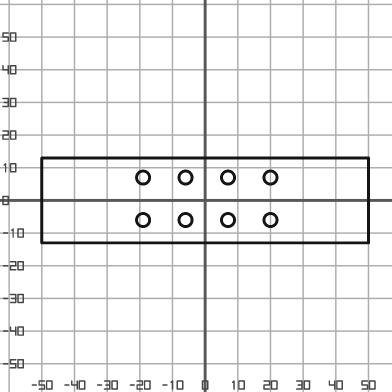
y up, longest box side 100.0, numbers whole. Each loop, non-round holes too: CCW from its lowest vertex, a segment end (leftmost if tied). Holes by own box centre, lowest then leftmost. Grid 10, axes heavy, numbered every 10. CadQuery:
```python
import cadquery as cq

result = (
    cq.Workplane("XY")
    .moveTo(-50.0, -13.0)
    .lineTo(50.0, -13.0)
    .lineTo(50.0, 13.0)
    .lineTo(-50.0, 13.0)
    .close()
    .moveTo(-19.0, -6.0)
    .circle(2.0)
    .moveTo(-6.0, -6.0)
    .circle(2.0)
    .moveTo(7.0, -6.0)
    .circle(2.0)
    .moveTo(20.0, -6.0)
    .circle(2.0)
    .moveTo(-19.0, 7.0)
    .circle(2.0)
    .moveTo(-6.0, 7.0)
    .circle(2.0)
    .moveTo(7.0, 7.0)
    .circle(2.0)
    .moveTo(20.0, 7.0)
    .circle(2.0)
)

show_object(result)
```